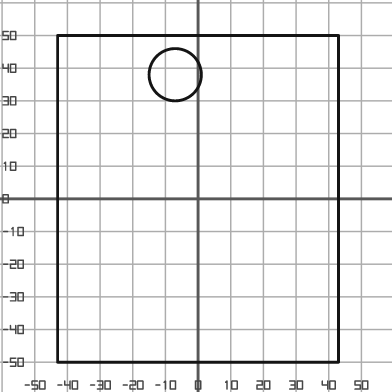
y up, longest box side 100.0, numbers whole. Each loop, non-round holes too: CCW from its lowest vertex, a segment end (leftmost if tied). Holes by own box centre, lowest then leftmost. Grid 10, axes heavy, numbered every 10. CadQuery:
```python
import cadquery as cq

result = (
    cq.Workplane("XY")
    .moveTo(-43.0, -50.0)
    .lineTo(43.0, -50.0)
    .lineTo(43.0, 50.0)
    .lineTo(-43.0, 50.0)
    .close()
    .moveTo(-7.0, 38.0)
    .circle(8.0)
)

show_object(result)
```